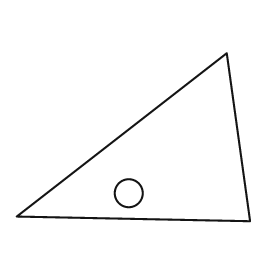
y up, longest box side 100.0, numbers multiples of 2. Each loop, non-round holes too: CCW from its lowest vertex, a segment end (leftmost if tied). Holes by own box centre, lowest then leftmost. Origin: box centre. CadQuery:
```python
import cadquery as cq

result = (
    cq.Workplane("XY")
    .moveTo(50.0, -36.0)
    .lineTo(40.0, 36.0)
    .lineTo(-50.0, -34.0)
    .close()
    .moveTo(-2.0, -24.0)
    .circle(6.0)
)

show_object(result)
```